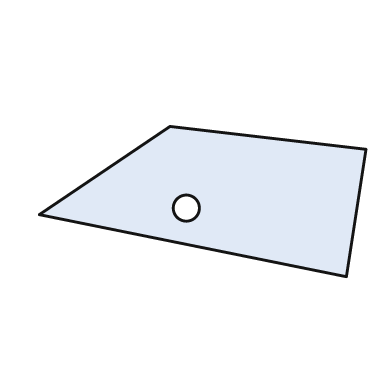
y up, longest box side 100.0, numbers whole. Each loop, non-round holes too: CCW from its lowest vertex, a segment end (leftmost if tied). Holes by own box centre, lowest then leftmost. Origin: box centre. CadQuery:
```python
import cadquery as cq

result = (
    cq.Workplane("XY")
    .moveTo(44.0, -23.0)
    .lineTo(50.0, 16.0)
    .lineTo(-10.0, 23.0)
    .lineTo(-50.0, -4.0)
    .close()
    .moveTo(-5.0, -2.0)
    .circle(4.0)
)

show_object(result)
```